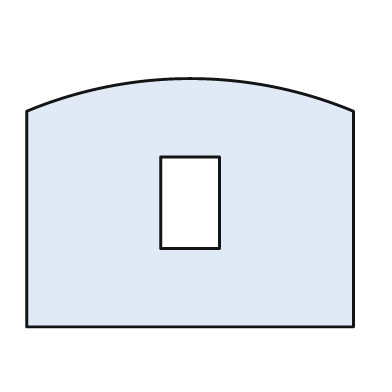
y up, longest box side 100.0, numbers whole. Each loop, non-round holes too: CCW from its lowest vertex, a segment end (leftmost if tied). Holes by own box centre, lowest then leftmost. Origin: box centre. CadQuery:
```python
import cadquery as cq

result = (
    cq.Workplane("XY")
    .moveTo(-50.0, -38.0)
    .lineTo(50.0, -38.0)
    .lineTo(50.0, 28.0)
    .threePointArc((0.0, 38.0), (-50.0, 28.0))
    .close()
    .moveTo(-9.0, -14.0)
    .lineTo(9.0, -14.0)
    .lineTo(9.0, 14.0)
    .lineTo(-9.0, 14.0)
    .close()
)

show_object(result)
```